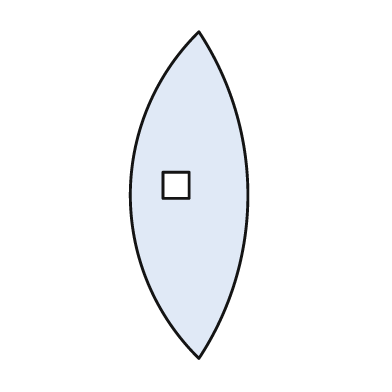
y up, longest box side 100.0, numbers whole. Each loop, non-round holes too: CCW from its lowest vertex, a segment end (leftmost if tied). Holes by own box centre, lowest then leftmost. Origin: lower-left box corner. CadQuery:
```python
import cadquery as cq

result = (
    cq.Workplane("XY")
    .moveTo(21.0, 0.0)
    .threePointArc((36.0, 50.0), (21.0, 100.0))
    .threePointArc((0.0, 50.0), (21.0, 0.0))
    .close()
    .moveTo(10.0, 49.0)
    .lineTo(18.0, 49.0)
    .lineTo(18.0, 57.0)
    .lineTo(10.0, 57.0)
    .close()
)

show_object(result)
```